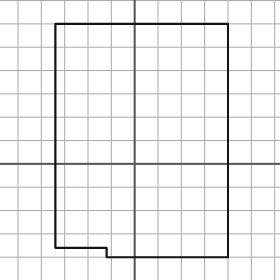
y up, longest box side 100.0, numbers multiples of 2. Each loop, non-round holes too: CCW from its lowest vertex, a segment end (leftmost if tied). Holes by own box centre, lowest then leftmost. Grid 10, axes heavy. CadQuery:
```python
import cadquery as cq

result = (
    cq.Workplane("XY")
    .moveTo(-12.0, -40.0)
    .lineTo(40.0, -40.0)
    .lineTo(40.0, 60.0)
    .lineTo(-34.0, 60.0)
    .lineTo(-34.0, -36.0)
    .lineTo(-12.0, -36.0)
    .close()
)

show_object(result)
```